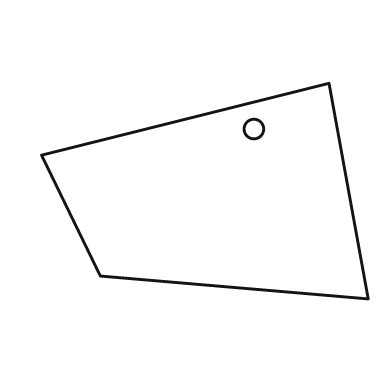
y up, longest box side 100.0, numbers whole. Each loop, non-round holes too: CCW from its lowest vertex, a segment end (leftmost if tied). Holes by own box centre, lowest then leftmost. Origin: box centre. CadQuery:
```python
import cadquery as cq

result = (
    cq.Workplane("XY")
    .moveTo(50.0, -33.0)
    .lineTo(38.0, 33.0)
    .lineTo(-50.0, 11.0)
    .lineTo(-32.0, -26.0)
    .close()
    .moveTo(15.0, 19.0)
    .circle(3.0)
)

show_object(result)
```